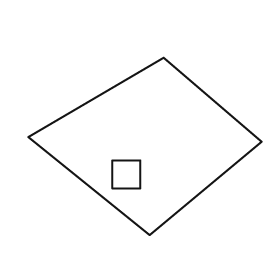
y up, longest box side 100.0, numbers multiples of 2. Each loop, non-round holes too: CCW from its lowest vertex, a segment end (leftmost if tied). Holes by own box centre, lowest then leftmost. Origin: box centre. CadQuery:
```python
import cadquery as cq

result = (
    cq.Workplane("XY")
    .moveTo(2.0, -38.0)
    .lineTo(50.0, 2.0)
    .lineTo(8.0, 38.0)
    .lineTo(-50.0, 4.0)
    .close()
    .moveTo(-14.0, -18.0)
    .lineTo(-2.0, -18.0)
    .lineTo(-2.0, -6.0)
    .lineTo(-14.0, -6.0)
    .close()
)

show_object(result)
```